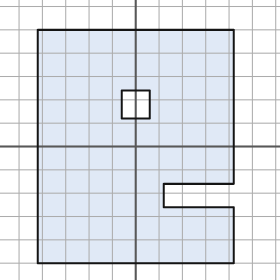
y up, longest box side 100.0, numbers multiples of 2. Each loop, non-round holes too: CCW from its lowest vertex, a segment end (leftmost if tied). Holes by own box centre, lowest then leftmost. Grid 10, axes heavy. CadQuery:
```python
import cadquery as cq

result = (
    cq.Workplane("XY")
    .moveTo(-42.0, -50.0)
    .lineTo(42.0, -50.0)
    .lineTo(42.0, -26.0)
    .lineTo(12.0, -26.0)
    .lineTo(12.0, -16.0)
    .lineTo(42.0, -16.0)
    .lineTo(42.0, 50.0)
    .lineTo(-42.0, 50.0)
    .close()
    .moveTo(-6.0, 12.0)
    .lineTo(6.0, 12.0)
    .lineTo(6.0, 24.0)
    .lineTo(-6.0, 24.0)
    .close()
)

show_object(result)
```